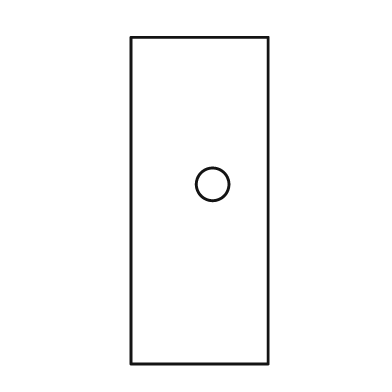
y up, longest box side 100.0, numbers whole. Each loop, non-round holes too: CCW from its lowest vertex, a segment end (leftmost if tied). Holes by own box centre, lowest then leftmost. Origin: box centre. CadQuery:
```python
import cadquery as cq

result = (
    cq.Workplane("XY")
    .moveTo(-21.0, -50.0)
    .lineTo(21.0, -50.0)
    .lineTo(21.0, 50.0)
    .lineTo(-21.0, 50.0)
    .close()
    .moveTo(4.0, 5.0)
    .circle(5.0)
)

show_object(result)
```